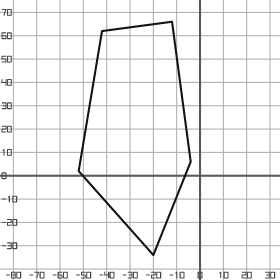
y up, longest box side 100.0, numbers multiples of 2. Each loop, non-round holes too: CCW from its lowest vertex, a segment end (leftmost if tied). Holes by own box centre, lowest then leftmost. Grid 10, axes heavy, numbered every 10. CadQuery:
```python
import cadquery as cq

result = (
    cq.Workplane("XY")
    .moveTo(-20.0, -34.0)
    .lineTo(-4.0, 6.0)
    .lineTo(-12.0, 66.0)
    .lineTo(-42.0, 62.0)
    .lineTo(-52.0, 2.0)
    .close()
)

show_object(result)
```